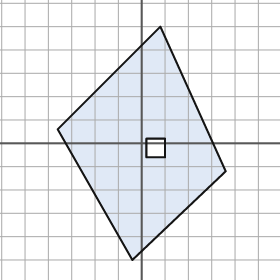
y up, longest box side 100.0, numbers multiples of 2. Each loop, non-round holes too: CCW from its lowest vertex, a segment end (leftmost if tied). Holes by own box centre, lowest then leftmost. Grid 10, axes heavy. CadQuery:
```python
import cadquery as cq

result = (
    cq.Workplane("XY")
    .moveTo(-4.0, -50.0)
    .lineTo(36.0, -12.0)
    .lineTo(8.0, 50.0)
    .lineTo(-36.0, 6.0)
    .close()
    .moveTo(2.0, -6.0)
    .lineTo(10.0, -6.0)
    .lineTo(10.0, 2.0)
    .lineTo(2.0, 2.0)
    .close()
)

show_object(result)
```